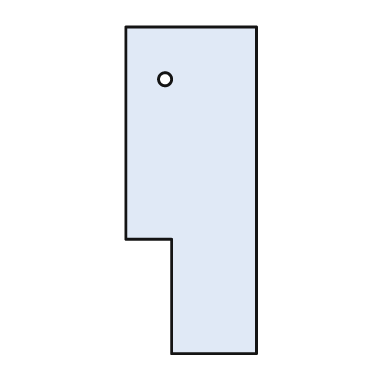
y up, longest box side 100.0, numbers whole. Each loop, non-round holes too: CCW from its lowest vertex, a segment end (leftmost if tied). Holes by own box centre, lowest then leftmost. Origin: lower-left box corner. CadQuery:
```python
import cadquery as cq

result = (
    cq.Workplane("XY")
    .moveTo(14.0, 0.0)
    .lineTo(40.0, 0.0)
    .lineTo(40.0, 100.0)
    .lineTo(0.0, 100.0)
    .lineTo(0.0, 35.0)
    .lineTo(14.0, 35.0)
    .close()
    .moveTo(12.0, 84.0)
    .circle(2.0)
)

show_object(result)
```